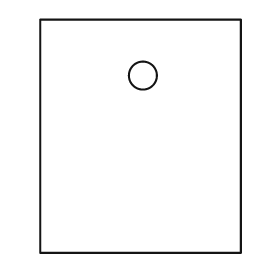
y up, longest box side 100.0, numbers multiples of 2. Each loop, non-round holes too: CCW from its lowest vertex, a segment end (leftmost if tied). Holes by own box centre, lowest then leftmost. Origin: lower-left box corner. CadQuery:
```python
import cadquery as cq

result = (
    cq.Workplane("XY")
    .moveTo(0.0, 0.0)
    .lineTo(86.0, 0.0)
    .lineTo(86.0, 100.0)
    .lineTo(0.0, 100.0)
    .close()
    .moveTo(44.0, 76.0)
    .circle(6.0)
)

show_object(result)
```